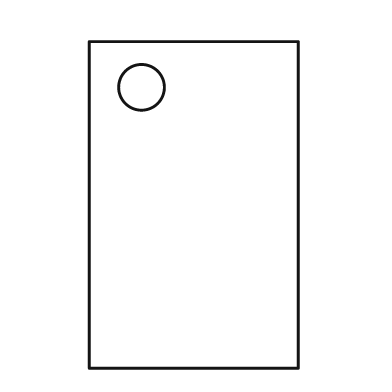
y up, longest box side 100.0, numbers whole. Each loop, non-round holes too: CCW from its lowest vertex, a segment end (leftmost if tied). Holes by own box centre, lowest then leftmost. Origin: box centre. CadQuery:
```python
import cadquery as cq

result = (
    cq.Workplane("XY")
    .moveTo(-32.0, -50.0)
    .lineTo(32.0, -50.0)
    .lineTo(32.0, 50.0)
    .lineTo(-32.0, 50.0)
    .close()
    .moveTo(-16.0, 36.0)
    .circle(7.0)
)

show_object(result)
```